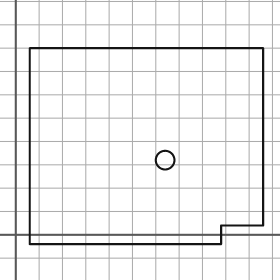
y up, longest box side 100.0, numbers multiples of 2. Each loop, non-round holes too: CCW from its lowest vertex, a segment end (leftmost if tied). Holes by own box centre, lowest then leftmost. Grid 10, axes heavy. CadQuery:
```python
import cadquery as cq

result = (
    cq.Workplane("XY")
    .moveTo(6.0, -4.0)
    .lineTo(88.0, -4.0)
    .lineTo(88.0, 4.0)
    .lineTo(106.0, 4.0)
    .lineTo(106.0, 80.0)
    .lineTo(6.0, 80.0)
    .close()
    .moveTo(64.0, 32.0)
    .circle(4.0)
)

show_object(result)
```